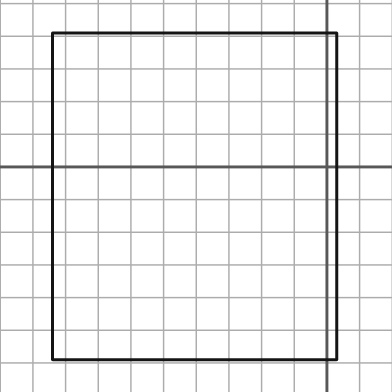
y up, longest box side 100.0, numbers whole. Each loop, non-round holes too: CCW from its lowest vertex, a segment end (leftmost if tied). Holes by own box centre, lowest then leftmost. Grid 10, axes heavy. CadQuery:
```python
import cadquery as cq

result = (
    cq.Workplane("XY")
    .moveTo(-84.0, -59.0)
    .lineTo(3.0, -59.0)
    .lineTo(3.0, 41.0)
    .lineTo(-84.0, 41.0)
    .close()
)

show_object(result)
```